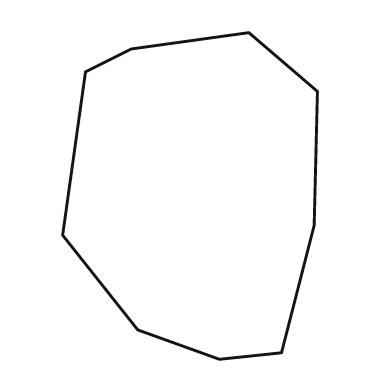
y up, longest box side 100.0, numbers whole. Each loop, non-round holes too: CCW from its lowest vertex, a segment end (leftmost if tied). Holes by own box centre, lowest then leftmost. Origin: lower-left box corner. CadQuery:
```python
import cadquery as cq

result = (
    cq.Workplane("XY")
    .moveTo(48.0, 0.0)
    .lineTo(67.0, 2.0)
    .lineTo(77.0, 41.0)
    .lineTo(78.0, 82.0)
    .lineTo(57.0, 100.0)
    .lineTo(21.0, 95.0)
    .lineTo(7.0, 88.0)
    .lineTo(0.0, 38.0)
    .lineTo(23.0, 9.0)
    .close()
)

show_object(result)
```